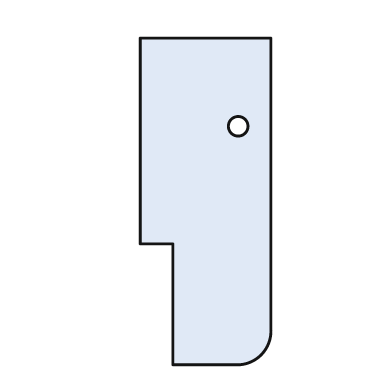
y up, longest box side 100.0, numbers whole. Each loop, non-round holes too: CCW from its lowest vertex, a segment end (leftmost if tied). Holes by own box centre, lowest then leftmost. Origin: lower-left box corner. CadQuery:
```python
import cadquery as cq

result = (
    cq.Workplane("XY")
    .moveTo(10.0, 0.0)
    .lineTo(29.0, 0.0)
    .threePointArc((37.0, 3.0), (40.0, 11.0))
    .lineTo(40.0, 100.0)
    .lineTo(0.0, 100.0)
    .lineTo(0.0, 37.0)
    .lineTo(10.0, 37.0)
    .close()
    .moveTo(30.0, 73.0)
    .circle(3.0)
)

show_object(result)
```